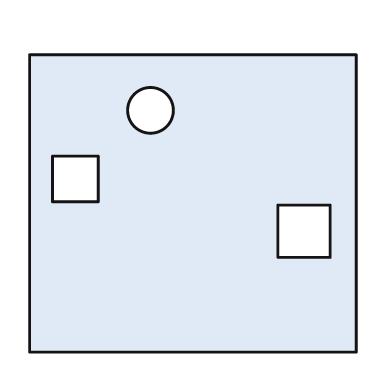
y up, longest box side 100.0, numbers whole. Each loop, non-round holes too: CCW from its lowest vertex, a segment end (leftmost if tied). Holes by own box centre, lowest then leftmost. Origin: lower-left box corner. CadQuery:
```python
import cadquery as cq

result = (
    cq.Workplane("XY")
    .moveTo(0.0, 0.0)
    .lineTo(100.0, 0.0)
    .lineTo(100.0, 91.0)
    .lineTo(0.0, 91.0)
    .close()
    .moveTo(76.0, 29.0)
    .lineTo(92.0, 29.0)
    .lineTo(92.0, 45.0)
    .lineTo(76.0, 45.0)
    .close()
    .moveTo(7.0, 46.0)
    .lineTo(21.0, 46.0)
    .lineTo(21.0, 60.0)
    .lineTo(7.0, 60.0)
    .close()
    .moveTo(37.0, 74.0)
    .circle(7.0)
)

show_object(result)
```